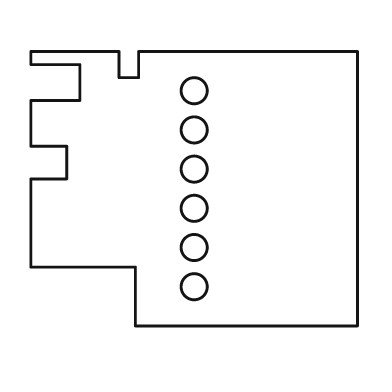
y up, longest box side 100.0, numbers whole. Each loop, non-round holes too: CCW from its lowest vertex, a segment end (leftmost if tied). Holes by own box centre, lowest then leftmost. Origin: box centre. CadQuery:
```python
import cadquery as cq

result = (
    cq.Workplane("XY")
    .moveTo(-18.0, -42.0)
    .lineTo(50.0, -42.0)
    .lineTo(50.0, 42.0)
    .lineTo(-17.0, 42.0)
    .lineTo(-17.0, 34.0)
    .lineTo(-23.0, 34.0)
    .lineTo(-23.0, 42.0)
    .lineTo(-50.0, 42.0)
    .lineTo(-50.0, 38.0)
    .lineTo(-35.0, 38.0)
    .lineTo(-35.0, 27.0)
    .lineTo(-50.0, 27.0)
    .lineTo(-50.0, 13.0)
    .lineTo(-39.0, 13.0)
    .lineTo(-39.0, 3.0)
    .lineTo(-50.0, 3.0)
    .lineTo(-50.0, -24.0)
    .lineTo(-18.0, -24.0)
    .close()
    .moveTo(0.0, -30.0)
    .circle(4.0)
    .moveTo(0.0, -18.0)
    .circle(4.0)
    .moveTo(0.0, -6.0)
    .circle(4.0)
    .moveTo(0.0, 6.0)
    .circle(4.0)
    .moveTo(0.0, 18.0)
    .circle(4.0)
    .moveTo(0.0, 30.0)
    .circle(4.0)
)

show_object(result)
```